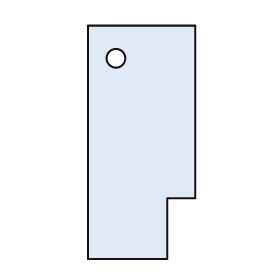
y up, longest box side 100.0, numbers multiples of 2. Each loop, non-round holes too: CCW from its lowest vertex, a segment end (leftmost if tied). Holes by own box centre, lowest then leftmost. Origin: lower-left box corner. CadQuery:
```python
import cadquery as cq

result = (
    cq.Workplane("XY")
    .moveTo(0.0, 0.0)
    .lineTo(34.0, 0.0)
    .lineTo(34.0, 26.0)
    .lineTo(46.0, 26.0)
    .lineTo(46.0, 100.0)
    .lineTo(0.0, 100.0)
    .close()
    .moveTo(12.0, 86.0)
    .circle(4.0)
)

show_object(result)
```